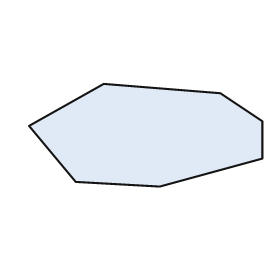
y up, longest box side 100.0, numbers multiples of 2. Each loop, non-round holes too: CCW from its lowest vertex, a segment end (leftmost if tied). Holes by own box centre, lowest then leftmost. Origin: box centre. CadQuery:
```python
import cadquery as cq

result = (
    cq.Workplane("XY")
    .moveTo(6.0, -22.0)
    .lineTo(50.0, -10.0)
    .lineTo(50.0, 6.0)
    .lineTo(32.0, 18.0)
    .lineTo(-18.0, 22.0)
    .lineTo(-50.0, 4.0)
    .lineTo(-30.0, -20.0)
    .close()
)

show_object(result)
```